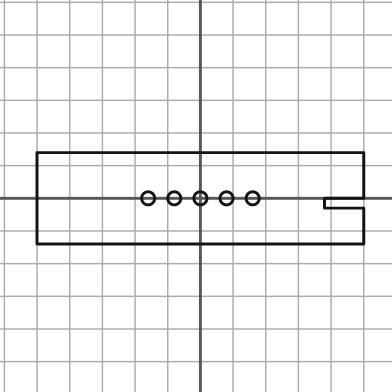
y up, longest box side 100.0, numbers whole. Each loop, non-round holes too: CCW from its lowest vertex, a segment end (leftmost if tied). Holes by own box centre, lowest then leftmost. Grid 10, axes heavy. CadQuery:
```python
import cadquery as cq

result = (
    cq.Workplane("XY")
    .moveTo(-50.0, -14.0)
    .lineTo(50.0, -14.0)
    .lineTo(50.0, -3.0)
    .lineTo(38.0, -3.0)
    .lineTo(38.0, 0.0)
    .lineTo(50.0, 0.0)
    .lineTo(50.0, 14.0)
    .lineTo(-50.0, 14.0)
    .close()
    .moveTo(-16.0, 0.0)
    .circle(2.0)
    .moveTo(-8.0, 0.0)
    .circle(2.0)
    .moveTo(0.0, 0.0)
    .circle(2.0)
    .moveTo(8.0, 0.0)
    .circle(2.0)
    .moveTo(16.0, 0.0)
    .circle(2.0)
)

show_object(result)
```